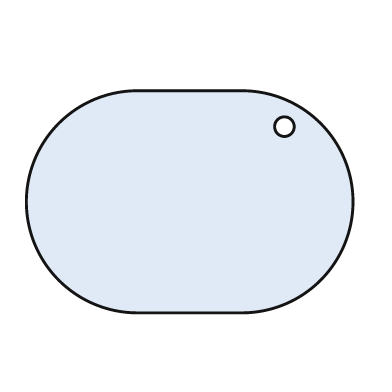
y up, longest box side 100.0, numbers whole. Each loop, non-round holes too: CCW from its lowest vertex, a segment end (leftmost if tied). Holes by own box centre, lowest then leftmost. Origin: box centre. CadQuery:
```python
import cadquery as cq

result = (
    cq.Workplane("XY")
    .moveTo(-16.0, -34.0)
    .lineTo(16.0, -34.0)
    .threePointArc((50.0, 0.0), (16.0, 34.0))
    .lineTo(-16.0, 34.0)
    .threePointArc((-50.0, 0.0), (-16.0, -34.0))
    .close()
    .moveTo(29.0, 23.0)
    .circle(3.0)
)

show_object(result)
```